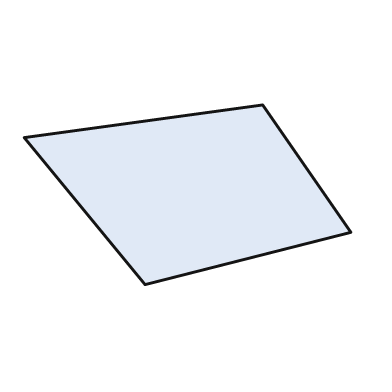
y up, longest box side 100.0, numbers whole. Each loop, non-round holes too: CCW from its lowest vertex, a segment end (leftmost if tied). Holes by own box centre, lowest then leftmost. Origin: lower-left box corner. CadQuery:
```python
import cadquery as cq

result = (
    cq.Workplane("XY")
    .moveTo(37.0, 0.0)
    .lineTo(100.0, 16.0)
    .lineTo(73.0, 55.0)
    .lineTo(0.0, 45.0)
    .close()
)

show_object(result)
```